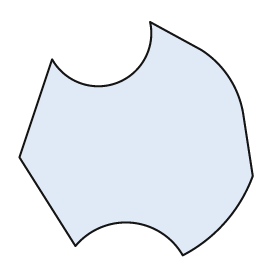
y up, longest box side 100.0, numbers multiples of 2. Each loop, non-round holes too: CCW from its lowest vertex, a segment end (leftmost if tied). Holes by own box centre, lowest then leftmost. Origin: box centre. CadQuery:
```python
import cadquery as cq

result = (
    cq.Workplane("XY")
    .moveTo(20.0, -50.0)
    .threePointArc((38.0, -36.0), (50.0, -16.0))
    .lineTo(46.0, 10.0)
    .threePointArc((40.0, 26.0), (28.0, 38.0))
    .lineTo(6.0, 50.0)
    .threePointArc((-8.0, 24.0), (-36.0, 34.0))
    .lineTo(-50.0, -8.0)
    .lineTo(-26.0, -46.0)
    .threePointArc((-2.0, -36.0), (20.0, -50.0))
    .close()
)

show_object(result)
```